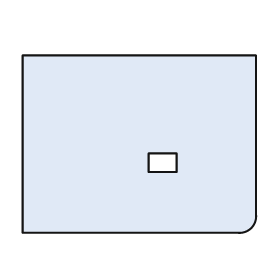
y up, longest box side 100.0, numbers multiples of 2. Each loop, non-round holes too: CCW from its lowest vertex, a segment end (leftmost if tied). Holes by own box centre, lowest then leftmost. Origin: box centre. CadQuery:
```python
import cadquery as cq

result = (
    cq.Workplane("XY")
    .moveTo(-50.0, -38.0)
    .lineTo(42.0, -38.0)
    .threePointArc((48.0, -36.0), (50.0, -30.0))
    .lineTo(50.0, 38.0)
    .lineTo(-50.0, 38.0)
    .close()
    .moveTo(4.0, -12.0)
    .lineTo(16.0, -12.0)
    .lineTo(16.0, -4.0)
    .lineTo(4.0, -4.0)
    .close()
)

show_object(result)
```